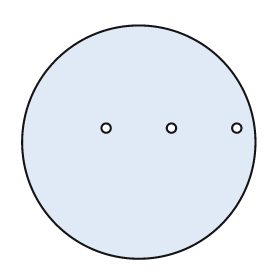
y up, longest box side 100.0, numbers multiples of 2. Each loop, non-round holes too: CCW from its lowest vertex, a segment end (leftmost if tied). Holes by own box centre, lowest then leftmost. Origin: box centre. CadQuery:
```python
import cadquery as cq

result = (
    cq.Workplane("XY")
    .moveTo(0.0, 0.0)
    .circle(50.0)
    .moveTo(-14.0, 6.0)
    .circle(2.0)
    .moveTo(14.0, 6.0)
    .circle(2.0)
    .moveTo(42.0, 6.0)
    .circle(2.0)
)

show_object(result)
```